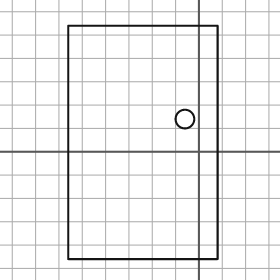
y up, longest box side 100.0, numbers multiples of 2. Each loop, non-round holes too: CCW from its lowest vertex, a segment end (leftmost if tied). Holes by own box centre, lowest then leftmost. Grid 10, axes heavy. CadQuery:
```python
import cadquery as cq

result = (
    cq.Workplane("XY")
    .moveTo(-56.0, -46.0)
    .lineTo(8.0, -46.0)
    .lineTo(8.0, 54.0)
    .lineTo(-56.0, 54.0)
    .close()
    .moveTo(-6.0, 14.0)
    .circle(4.0)
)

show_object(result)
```